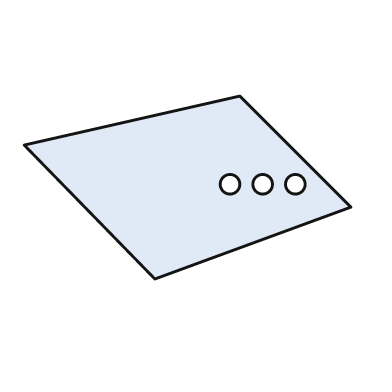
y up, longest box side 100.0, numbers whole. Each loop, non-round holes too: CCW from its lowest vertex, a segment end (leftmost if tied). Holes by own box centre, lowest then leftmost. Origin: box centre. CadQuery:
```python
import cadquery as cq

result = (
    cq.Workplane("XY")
    .moveTo(-10.0, -28.0)
    .lineTo(50.0, -6.0)
    .lineTo(16.0, 28.0)
    .lineTo(-50.0, 13.0)
    .close()
    .moveTo(13.0, 1.0)
    .circle(3.0)
    .moveTo(23.0, 1.0)
    .circle(3.0)
    .moveTo(33.0, 1.0)
    .circle(3.0)
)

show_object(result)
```